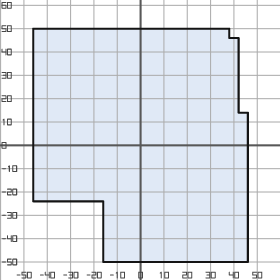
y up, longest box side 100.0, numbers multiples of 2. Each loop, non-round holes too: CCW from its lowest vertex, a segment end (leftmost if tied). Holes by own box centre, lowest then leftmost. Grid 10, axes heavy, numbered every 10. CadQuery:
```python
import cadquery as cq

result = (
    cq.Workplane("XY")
    .moveTo(-16.0, -50.0)
    .lineTo(46.0, -50.0)
    .lineTo(46.0, 14.0)
    .lineTo(42.0, 14.0)
    .lineTo(42.0, 46.0)
    .lineTo(38.0, 46.0)
    .lineTo(38.0, 50.0)
    .lineTo(-46.0, 50.0)
    .lineTo(-46.0, -24.0)
    .lineTo(-16.0, -24.0)
    .close()
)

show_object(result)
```